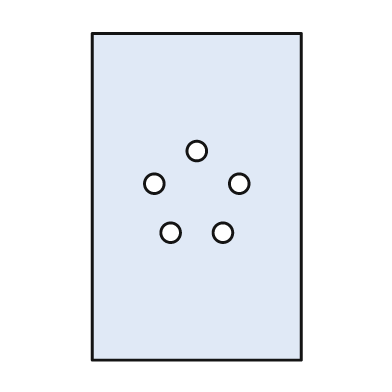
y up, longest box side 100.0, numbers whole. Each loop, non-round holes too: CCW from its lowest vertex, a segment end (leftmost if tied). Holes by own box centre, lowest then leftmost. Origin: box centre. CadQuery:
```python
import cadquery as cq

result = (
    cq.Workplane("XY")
    .moveTo(-32.0, -50.0)
    .lineTo(32.0, -50.0)
    .lineTo(32.0, 50.0)
    .lineTo(-32.0, 50.0)
    .close()
    .moveTo(-8.0, -11.0)
    .circle(3.0)
    .moveTo(8.0, -11.0)
    .circle(3.0)
    .moveTo(-13.0, 4.0)
    .circle(3.0)
    .moveTo(13.0, 4.0)
    .circle(3.0)
    .moveTo(0.0, 14.0)
    .circle(3.0)
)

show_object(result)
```